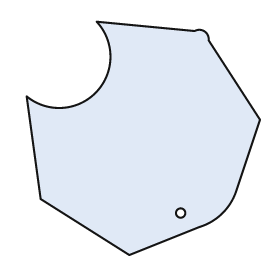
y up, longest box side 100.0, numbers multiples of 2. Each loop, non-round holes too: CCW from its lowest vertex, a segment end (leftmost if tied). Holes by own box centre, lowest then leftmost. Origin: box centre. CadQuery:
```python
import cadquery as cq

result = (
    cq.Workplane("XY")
    .moveTo(-6.0, -50.0)
    .lineTo(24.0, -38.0)
    .threePointArc((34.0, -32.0), (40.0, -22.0))
    .lineTo(50.0, 8.0)
    .lineTo(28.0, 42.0)
    .threePointArc((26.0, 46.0), (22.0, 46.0))
    .lineTo(-20.0, 50.0)
    .threePointArc((-20.0, 20.0), (-50.0, 18.0))
    .lineTo(-44.0, -26.0)
    .close()
    .moveTo(16.0, -32.0)
    .circle(2.0)
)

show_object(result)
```